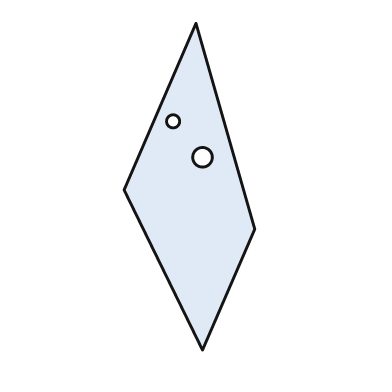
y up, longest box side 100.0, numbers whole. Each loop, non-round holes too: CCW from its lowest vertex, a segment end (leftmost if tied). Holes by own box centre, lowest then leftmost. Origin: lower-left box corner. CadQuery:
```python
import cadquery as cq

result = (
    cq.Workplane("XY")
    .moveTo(24.0, 0.0)
    .lineTo(40.0, 37.0)
    .lineTo(22.0, 100.0)
    .lineTo(0.0, 49.0)
    .close()
    .moveTo(24.0, 59.0)
    .circle(3.0)
    .moveTo(15.0, 70.0)
    .circle(2.0)
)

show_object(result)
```